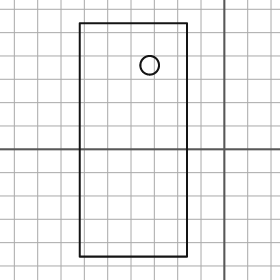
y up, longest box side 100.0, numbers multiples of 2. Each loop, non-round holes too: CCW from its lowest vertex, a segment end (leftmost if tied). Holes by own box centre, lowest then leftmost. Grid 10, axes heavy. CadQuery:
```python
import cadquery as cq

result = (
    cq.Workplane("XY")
    .moveTo(-62.0, -46.0)
    .lineTo(-16.0, -46.0)
    .lineTo(-16.0, 54.0)
    .lineTo(-62.0, 54.0)
    .close()
    .moveTo(-32.0, 36.0)
    .circle(4.0)
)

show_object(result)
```